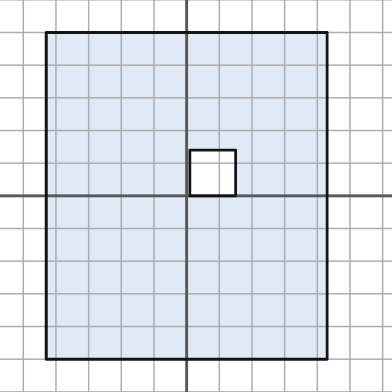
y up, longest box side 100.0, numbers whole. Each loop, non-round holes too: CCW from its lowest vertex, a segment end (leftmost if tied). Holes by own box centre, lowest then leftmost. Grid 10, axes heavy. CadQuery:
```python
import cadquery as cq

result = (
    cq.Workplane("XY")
    .moveTo(-43.0, -50.0)
    .lineTo(43.0, -50.0)
    .lineTo(43.0, 50.0)
    .lineTo(-43.0, 50.0)
    .close()
    .moveTo(1.0, 0.0)
    .lineTo(15.0, 0.0)
    .lineTo(15.0, 14.0)
    .lineTo(1.0, 14.0)
    .close()
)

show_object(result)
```